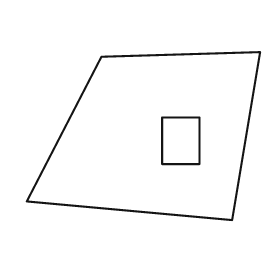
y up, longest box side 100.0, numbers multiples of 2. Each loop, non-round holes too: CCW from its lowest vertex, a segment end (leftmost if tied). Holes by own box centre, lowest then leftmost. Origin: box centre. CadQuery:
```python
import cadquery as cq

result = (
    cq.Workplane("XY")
    .moveTo(38.0, -36.0)
    .lineTo(50.0, 36.0)
    .lineTo(-18.0, 34.0)
    .lineTo(-50.0, -28.0)
    .close()
    .moveTo(8.0, -12.0)
    .lineTo(24.0, -12.0)
    .lineTo(24.0, 8.0)
    .lineTo(8.0, 8.0)
    .close()
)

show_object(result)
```